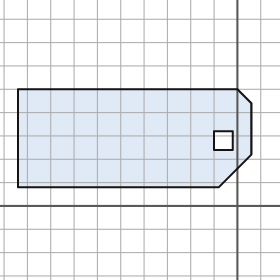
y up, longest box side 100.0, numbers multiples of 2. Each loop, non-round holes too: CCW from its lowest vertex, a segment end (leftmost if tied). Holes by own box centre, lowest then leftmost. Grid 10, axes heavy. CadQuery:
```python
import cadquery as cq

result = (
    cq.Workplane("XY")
    .moveTo(-94.0, 8.0)
    .lineTo(-8.0, 8.0)
    .lineTo(6.0, 22.0)
    .lineTo(6.0, 44.0)
    .lineTo(0.0, 50.0)
    .lineTo(-94.0, 50.0)
    .close()
    .moveTo(-10.0, 24.0)
    .lineTo(-2.0, 24.0)
    .lineTo(-2.0, 32.0)
    .lineTo(-10.0, 32.0)
    .close()
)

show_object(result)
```